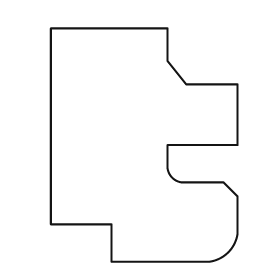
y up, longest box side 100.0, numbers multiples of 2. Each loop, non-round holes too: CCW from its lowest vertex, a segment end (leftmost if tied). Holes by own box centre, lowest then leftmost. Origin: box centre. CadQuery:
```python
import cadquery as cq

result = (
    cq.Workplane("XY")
    .moveTo(-14.0, -50.0)
    .lineTo(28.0, -50.0)
    .threePointArc((36.0, -46.0), (40.0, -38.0))
    .lineTo(40.0, -22.0)
    .lineTo(34.0, -16.0)
    .lineTo(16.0, -16.0)
    .threePointArc((12.0, -14.0), (10.0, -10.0))
    .lineTo(10.0, 0.0)
    .lineTo(40.0, 0.0)
    .lineTo(40.0, 26.0)
    .lineTo(18.0, 26.0)
    .lineTo(10.0, 36.0)
    .lineTo(10.0, 50.0)
    .lineTo(-40.0, 50.0)
    .lineTo(-40.0, -34.0)
    .lineTo(-14.0, -34.0)
    .close()
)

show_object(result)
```